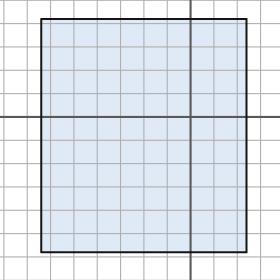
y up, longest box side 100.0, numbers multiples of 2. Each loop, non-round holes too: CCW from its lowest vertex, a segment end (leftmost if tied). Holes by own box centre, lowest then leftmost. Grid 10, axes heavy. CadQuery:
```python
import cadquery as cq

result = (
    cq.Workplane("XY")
    .moveTo(-64.0, -58.0)
    .lineTo(24.0, -58.0)
    .lineTo(24.0, 42.0)
    .lineTo(-64.0, 42.0)
    .close()
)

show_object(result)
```